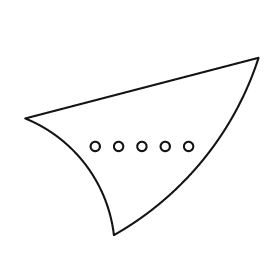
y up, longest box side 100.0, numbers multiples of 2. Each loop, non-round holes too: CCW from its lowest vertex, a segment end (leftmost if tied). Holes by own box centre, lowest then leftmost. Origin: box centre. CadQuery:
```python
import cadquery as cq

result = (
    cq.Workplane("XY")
    .moveTo(-12.0, -38.0)
    .threePointArc((26.0, -6.0), (50.0, 38.0))
    .lineTo(-50.0, 12.0)
    .threePointArc((-24.0, -8.0), (-12.0, -38.0))
    .close()
    .moveTo(-20.0, 0.0)
    .circle(2.0)
    .moveTo(-10.0, 0.0)
    .circle(2.0)
    .moveTo(0.0, 0.0)
    .circle(2.0)
    .moveTo(10.0, 0.0)
    .circle(2.0)
    .moveTo(20.0, 0.0)
    .circle(2.0)
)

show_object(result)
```